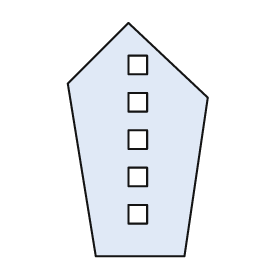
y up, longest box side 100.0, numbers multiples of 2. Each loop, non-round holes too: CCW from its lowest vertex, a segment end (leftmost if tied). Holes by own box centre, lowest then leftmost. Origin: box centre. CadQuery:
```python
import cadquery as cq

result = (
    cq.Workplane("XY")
    .moveTo(-18.0, -50.0)
    .lineTo(20.0, -50.0)
    .lineTo(30.0, 18.0)
    .lineTo(-4.0, 50.0)
    .lineTo(-30.0, 24.0)
    .close()
    .moveTo(-4.0, -36.0)
    .lineTo(4.0, -36.0)
    .lineTo(4.0, -28.0)
    .lineTo(-4.0, -28.0)
    .close()
    .moveTo(-4.0, -20.0)
    .lineTo(4.0, -20.0)
    .lineTo(4.0, -12.0)
    .lineTo(-4.0, -12.0)
    .close()
    .moveTo(-4.0, -4.0)
    .lineTo(4.0, -4.0)
    .lineTo(4.0, 4.0)
    .lineTo(-4.0, 4.0)
    .close()
    .moveTo(-4.0, 12.0)
    .lineTo(4.0, 12.0)
    .lineTo(4.0, 20.0)
    .lineTo(-4.0, 20.0)
    .close()
    .moveTo(-4.0, 28.0)
    .lineTo(4.0, 28.0)
    .lineTo(4.0, 36.0)
    .lineTo(-4.0, 36.0)
    .close()
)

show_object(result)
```